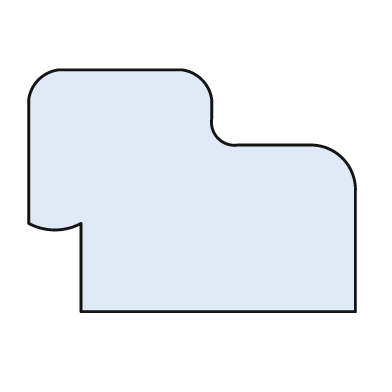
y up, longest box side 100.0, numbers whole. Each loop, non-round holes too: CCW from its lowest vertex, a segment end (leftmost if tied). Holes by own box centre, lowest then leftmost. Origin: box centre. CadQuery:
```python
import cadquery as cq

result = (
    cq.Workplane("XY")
    .moveTo(-34.0, -37.0)
    .lineTo(50.0, -37.0)
    .lineTo(50.0, 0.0)
    .threePointArc((46.0, 10.0), (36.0, 14.0))
    .lineTo(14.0, 14.0)
    .threePointArc((8.0, 16.0), (6.0, 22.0))
    .lineTo(6.0, 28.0)
    .threePointArc((3.0, 34.0), (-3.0, 37.0))
    .lineTo(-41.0, 37.0)
    .threePointArc((-47.0, 34.0), (-50.0, 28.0))
    .lineTo(-50.0, -10.0)
    .threePointArc((-42.0, -12.0), (-34.0, -10.0))
    .close()
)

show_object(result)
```